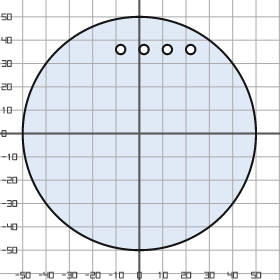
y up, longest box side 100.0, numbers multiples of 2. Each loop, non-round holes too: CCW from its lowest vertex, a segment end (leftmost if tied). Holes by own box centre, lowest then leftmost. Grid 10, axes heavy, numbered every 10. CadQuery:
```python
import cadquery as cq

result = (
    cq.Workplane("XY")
    .moveTo(0.0, 0.0)
    .circle(50.0)
    .moveTo(-8.0, 36.0)
    .circle(2.0)
    .moveTo(2.0, 36.0)
    .circle(2.0)
    .moveTo(12.0, 36.0)
    .circle(2.0)
    .moveTo(22.0, 36.0)
    .circle(2.0)
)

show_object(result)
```